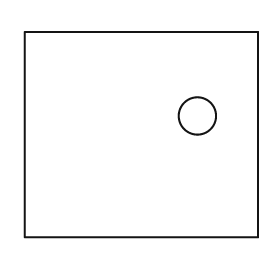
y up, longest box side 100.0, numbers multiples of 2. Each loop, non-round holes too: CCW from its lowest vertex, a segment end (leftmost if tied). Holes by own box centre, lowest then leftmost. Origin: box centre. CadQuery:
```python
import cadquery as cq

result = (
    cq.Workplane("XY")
    .moveTo(-50.0, -44.0)
    .lineTo(50.0, -44.0)
    .lineTo(50.0, 44.0)
    .lineTo(-50.0, 44.0)
    .close()
    .moveTo(24.0, 8.0)
    .circle(8.0)
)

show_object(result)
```